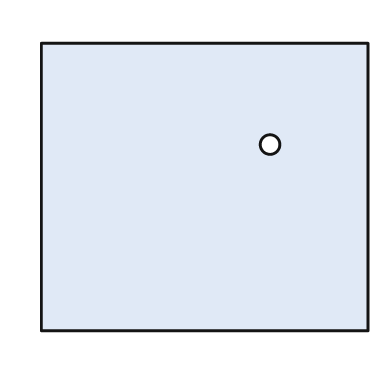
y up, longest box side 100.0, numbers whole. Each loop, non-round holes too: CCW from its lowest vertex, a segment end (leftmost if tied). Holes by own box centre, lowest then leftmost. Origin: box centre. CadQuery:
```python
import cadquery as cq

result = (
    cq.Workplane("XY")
    .moveTo(-50.0, -44.0)
    .lineTo(50.0, -44.0)
    .lineTo(50.0, 44.0)
    .lineTo(-50.0, 44.0)
    .close()
    .moveTo(20.0, 13.0)
    .circle(3.0)
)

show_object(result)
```